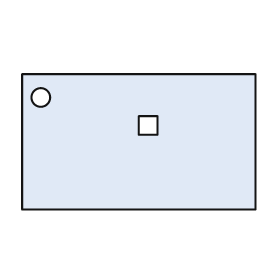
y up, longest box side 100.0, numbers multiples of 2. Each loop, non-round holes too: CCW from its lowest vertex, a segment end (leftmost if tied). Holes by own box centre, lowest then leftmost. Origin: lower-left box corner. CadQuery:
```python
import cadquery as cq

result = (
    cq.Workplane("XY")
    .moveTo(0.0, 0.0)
    .lineTo(100.0, 0.0)
    .lineTo(100.0, 58.0)
    .lineTo(0.0, 58.0)
    .close()
    .moveTo(50.0, 32.0)
    .lineTo(58.0, 32.0)
    .lineTo(58.0, 40.0)
    .lineTo(50.0, 40.0)
    .close()
    .moveTo(8.0, 48.0)
    .circle(4.0)
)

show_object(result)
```